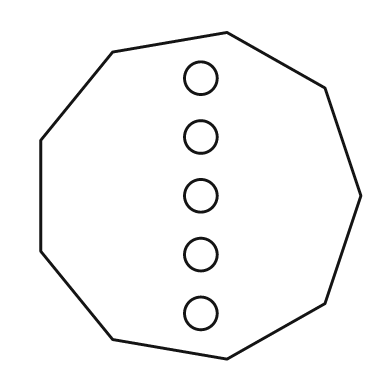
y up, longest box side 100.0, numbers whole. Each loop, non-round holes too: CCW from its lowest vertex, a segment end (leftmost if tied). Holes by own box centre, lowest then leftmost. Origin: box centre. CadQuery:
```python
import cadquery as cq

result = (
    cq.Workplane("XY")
    .moveTo(8.0, -50.0)
    .lineTo(38.0, -33.0)
    .lineTo(49.0, 0.0)
    .lineTo(38.0, 33.0)
    .lineTo(8.0, 50.0)
    .lineTo(-27.0, 44.0)
    .lineTo(-49.0, 17.0)
    .lineTo(-49.0, -17.0)
    .lineTo(-27.0, -44.0)
    .close()
    .moveTo(0.0, -36.0)
    .circle(5.0)
    .moveTo(0.0, -18.0)
    .circle(5.0)
    .moveTo(0.0, 0.0)
    .circle(5.0)
    .moveTo(0.0, 18.0)
    .circle(5.0)
    .moveTo(0.0, 36.0)
    .circle(5.0)
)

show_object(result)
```